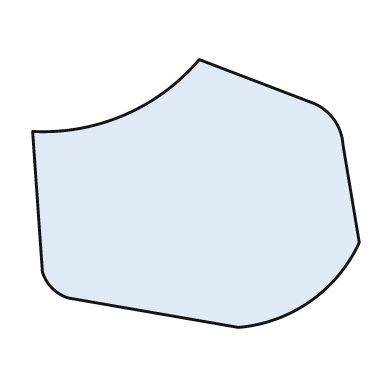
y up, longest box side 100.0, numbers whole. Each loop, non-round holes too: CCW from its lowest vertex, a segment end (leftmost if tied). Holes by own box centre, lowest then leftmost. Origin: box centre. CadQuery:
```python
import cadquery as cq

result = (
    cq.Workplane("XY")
    .moveTo(13.0, -41.0)
    .threePointArc((35.0, -33.0), (50.0, -15.0))
    .lineTo(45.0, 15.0)
    .threePointArc((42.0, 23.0), (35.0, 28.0))
    .lineTo(1.0, 41.0)
    .threePointArc((-22.0, 24.0), (-50.0, 19.0))
    .lineTo(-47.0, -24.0)
    .threePointArc((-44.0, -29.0), (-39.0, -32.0))
    .close()
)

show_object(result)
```